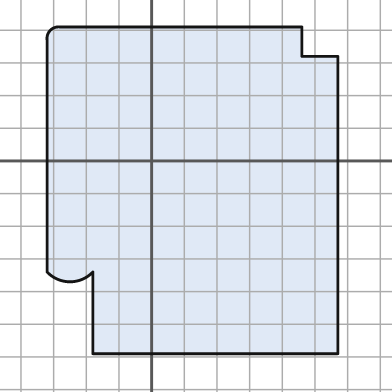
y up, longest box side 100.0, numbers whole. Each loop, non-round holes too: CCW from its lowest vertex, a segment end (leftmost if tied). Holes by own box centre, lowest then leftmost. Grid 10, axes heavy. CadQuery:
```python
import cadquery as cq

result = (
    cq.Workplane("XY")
    .moveTo(-18.0, -59.0)
    .lineTo(57.0, -59.0)
    .lineTo(57.0, 32.0)
    .lineTo(46.0, 32.0)
    .lineTo(46.0, 41.0)
    .lineTo(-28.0, 41.0)
    .threePointArc((-31.0, 40.0), (-32.0, 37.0))
    .lineTo(-32.0, -34.0)
    .threePointArc((-25.0, -37.0), (-18.0, -34.0))
    .close()
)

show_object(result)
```